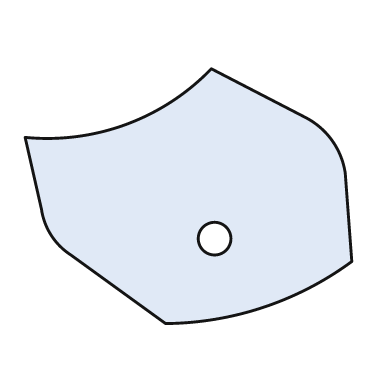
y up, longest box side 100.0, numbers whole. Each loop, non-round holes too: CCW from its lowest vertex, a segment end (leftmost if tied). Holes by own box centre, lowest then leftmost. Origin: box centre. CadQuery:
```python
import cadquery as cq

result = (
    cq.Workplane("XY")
    .moveTo(-7.0, -39.0)
    .threePointArc((23.0, -34.0), (50.0, -20.0))
    .lineTo(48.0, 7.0)
    .threePointArc((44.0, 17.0), (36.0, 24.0))
    .lineTo(7.0, 39.0)
    .threePointArc((-19.0, 22.0), (-50.0, 18.0))
    .lineTo(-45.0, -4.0)
    .threePointArc((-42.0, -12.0), (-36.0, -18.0))
    .close()
    .moveTo(8.0, -13.0)
    .circle(5.0)
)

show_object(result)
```